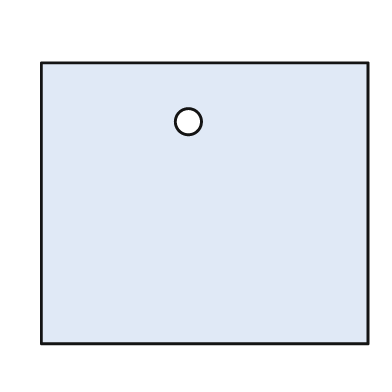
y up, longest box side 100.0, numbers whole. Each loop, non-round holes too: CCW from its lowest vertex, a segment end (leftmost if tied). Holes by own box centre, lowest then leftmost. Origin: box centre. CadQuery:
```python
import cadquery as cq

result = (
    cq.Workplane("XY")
    .moveTo(-50.0, -43.0)
    .lineTo(50.0, -43.0)
    .lineTo(50.0, 43.0)
    .lineTo(-50.0, 43.0)
    .close()
    .moveTo(-5.0, 25.0)
    .circle(4.0)
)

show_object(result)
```